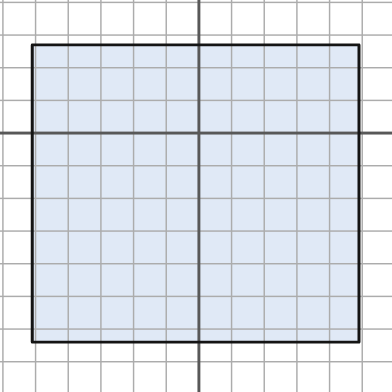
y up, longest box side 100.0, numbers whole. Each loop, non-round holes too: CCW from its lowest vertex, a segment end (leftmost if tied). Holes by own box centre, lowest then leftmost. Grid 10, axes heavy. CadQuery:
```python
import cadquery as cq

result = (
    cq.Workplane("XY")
    .moveTo(-51.0, -64.0)
    .lineTo(49.0, -64.0)
    .lineTo(49.0, 27.0)
    .lineTo(-51.0, 27.0)
    .close()
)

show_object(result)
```